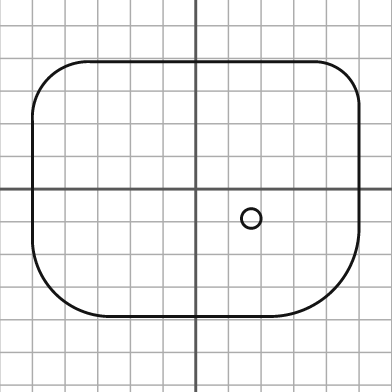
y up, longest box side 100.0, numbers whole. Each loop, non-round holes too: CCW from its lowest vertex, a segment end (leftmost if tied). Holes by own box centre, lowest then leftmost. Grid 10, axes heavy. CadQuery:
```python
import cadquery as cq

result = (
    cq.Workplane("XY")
    .moveTo(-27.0, -39.0)
    .lineTo(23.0, -39.0)
    .threePointArc((42.0, -31.0), (50.0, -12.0))
    .lineTo(50.0, 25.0)
    .threePointArc((46.0, 35.0), (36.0, 39.0))
    .lineTo(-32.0, 39.0)
    .threePointArc((-45.0, 34.0), (-50.0, 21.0))
    .lineTo(-50.0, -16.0)
    .threePointArc((-43.0, -32.0), (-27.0, -39.0))
    .close()
    .moveTo(17.0, -9.0)
    .circle(3.0)
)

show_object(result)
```